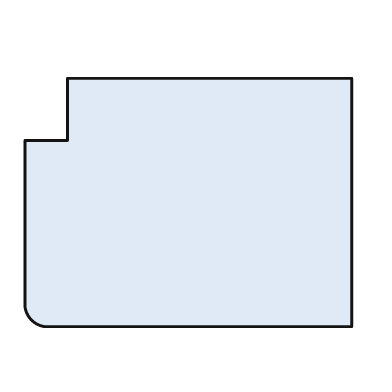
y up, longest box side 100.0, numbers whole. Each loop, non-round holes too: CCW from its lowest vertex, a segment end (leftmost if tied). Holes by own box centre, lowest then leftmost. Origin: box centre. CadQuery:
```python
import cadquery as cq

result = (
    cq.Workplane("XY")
    .moveTo(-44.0, -38.0)
    .lineTo(50.0, -38.0)
    .lineTo(50.0, 38.0)
    .lineTo(-37.0, 38.0)
    .lineTo(-37.0, 19.0)
    .lineTo(-50.0, 19.0)
    .lineTo(-50.0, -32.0)
    .threePointArc((-48.0, -36.0), (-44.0, -38.0))
    .close()
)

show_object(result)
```